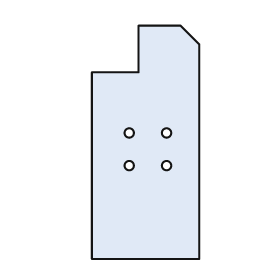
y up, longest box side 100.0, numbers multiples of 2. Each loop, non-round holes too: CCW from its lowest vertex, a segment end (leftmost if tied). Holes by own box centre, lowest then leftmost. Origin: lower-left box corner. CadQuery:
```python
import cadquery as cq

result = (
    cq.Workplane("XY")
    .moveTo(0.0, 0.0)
    .lineTo(46.0, 0.0)
    .lineTo(46.0, 92.0)
    .lineTo(38.0, 100.0)
    .lineTo(20.0, 100.0)
    .lineTo(20.0, 80.0)
    .lineTo(0.0, 80.0)
    .close()
    .moveTo(16.0, 40.0)
    .circle(2.0)
    .moveTo(32.0, 40.0)
    .circle(2.0)
    .moveTo(16.0, 54.0)
    .circle(2.0)
    .moveTo(32.0, 54.0)
    .circle(2.0)
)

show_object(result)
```